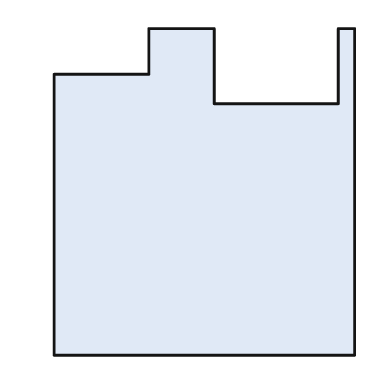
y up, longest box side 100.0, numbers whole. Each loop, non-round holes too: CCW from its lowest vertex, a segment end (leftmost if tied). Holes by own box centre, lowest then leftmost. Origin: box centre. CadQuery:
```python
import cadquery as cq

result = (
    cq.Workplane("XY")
    .moveTo(-46.0, -50.0)
    .lineTo(46.0, -50.0)
    .lineTo(46.0, 50.0)
    .lineTo(41.0, 50.0)
    .lineTo(41.0, 27.0)
    .lineTo(3.0, 27.0)
    .lineTo(3.0, 50.0)
    .lineTo(-17.0, 50.0)
    .lineTo(-17.0, 36.0)
    .lineTo(-46.0, 36.0)
    .close()
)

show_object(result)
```